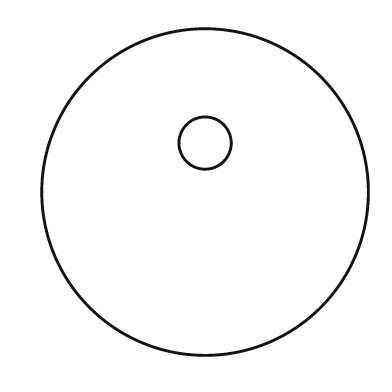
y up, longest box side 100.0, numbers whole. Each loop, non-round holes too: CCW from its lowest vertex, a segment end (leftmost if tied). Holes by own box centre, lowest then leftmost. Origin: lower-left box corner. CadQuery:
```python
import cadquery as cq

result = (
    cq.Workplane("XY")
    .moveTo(50.0, 50.0)
    .circle(50.0)
    .moveTo(50.0, 65.0)
    .circle(8.0)
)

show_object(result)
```